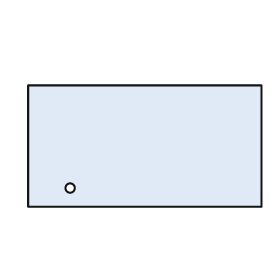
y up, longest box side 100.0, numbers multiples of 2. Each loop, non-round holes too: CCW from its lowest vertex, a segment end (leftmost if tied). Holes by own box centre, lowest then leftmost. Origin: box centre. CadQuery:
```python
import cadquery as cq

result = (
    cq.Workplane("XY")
    .moveTo(-50.0, -26.0)
    .lineTo(50.0, -26.0)
    .lineTo(50.0, 26.0)
    .lineTo(-50.0, 26.0)
    .close()
    .moveTo(-32.0, -18.0)
    .circle(2.0)
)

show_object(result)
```